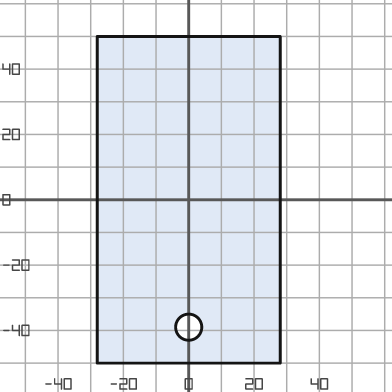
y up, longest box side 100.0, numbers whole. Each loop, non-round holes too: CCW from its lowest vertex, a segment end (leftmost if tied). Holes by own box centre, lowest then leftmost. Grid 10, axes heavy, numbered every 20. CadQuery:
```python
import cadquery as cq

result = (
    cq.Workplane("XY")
    .moveTo(-28.0, -50.0)
    .lineTo(28.0, -50.0)
    .lineTo(28.0, 50.0)
    .lineTo(-28.0, 50.0)
    .close()
    .moveTo(0.0, -39.0)
    .circle(4.0)
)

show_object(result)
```